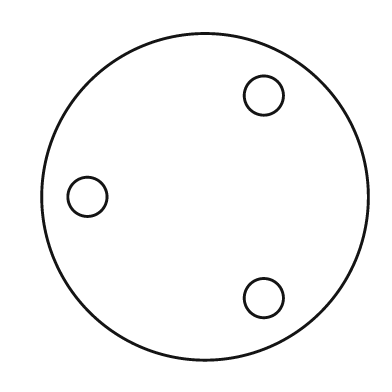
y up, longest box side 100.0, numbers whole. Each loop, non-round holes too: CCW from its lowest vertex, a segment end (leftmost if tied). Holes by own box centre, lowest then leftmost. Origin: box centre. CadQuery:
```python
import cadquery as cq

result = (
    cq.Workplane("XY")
    .moveTo(0.0, 0.0)
    .circle(50.0)
    .moveTo(18.0, -31.0)
    .circle(6.0)
    .moveTo(-36.0, 0.0)
    .circle(6.0)
    .moveTo(18.0, 31.0)
    .circle(6.0)
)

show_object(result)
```